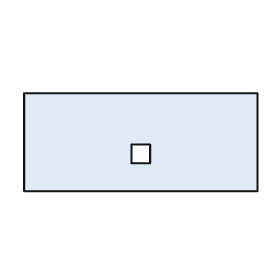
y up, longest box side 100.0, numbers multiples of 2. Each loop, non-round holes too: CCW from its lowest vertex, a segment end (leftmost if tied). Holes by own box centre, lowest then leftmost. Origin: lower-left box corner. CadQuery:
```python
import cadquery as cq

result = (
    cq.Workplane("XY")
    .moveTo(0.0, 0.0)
    .lineTo(100.0, 0.0)
    .lineTo(100.0, 42.0)
    .lineTo(0.0, 42.0)
    .close()
    .moveTo(46.0, 12.0)
    .lineTo(54.0, 12.0)
    .lineTo(54.0, 20.0)
    .lineTo(46.0, 20.0)
    .close()
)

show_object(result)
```